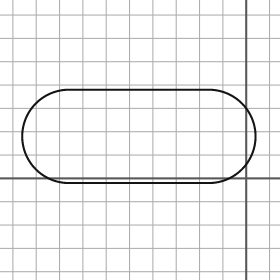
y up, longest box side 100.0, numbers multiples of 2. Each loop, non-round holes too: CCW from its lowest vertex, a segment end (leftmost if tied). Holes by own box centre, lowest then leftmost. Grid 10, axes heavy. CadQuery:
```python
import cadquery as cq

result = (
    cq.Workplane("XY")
    .moveTo(-76.0, -2.0)
    .lineTo(-16.0, -2.0)
    .threePointArc((4.0, 18.0), (-16.0, 38.0))
    .lineTo(-76.0, 38.0)
    .threePointArc((-96.0, 18.0), (-76.0, -2.0))
    .close()
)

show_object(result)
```